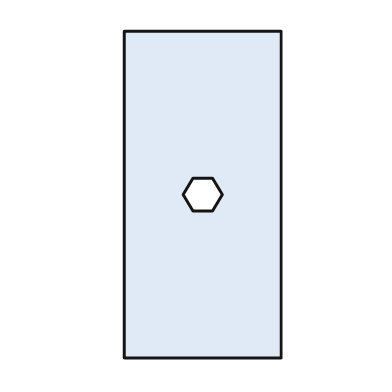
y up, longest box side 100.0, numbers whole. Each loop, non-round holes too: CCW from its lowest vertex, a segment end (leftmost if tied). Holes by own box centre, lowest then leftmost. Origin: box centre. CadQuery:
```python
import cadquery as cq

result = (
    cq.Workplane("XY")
    .moveTo(-24.0, -50.0)
    .lineTo(24.0, -50.0)
    .lineTo(24.0, 50.0)
    .lineTo(-24.0, 50.0)
    .close()
    .moveTo(-3.0, -5.0)
    .lineTo(3.0, -5.0)
    .lineTo(6.0, 0.0)
    .lineTo(3.0, 5.0)
    .lineTo(-3.0, 5.0)
    .lineTo(-6.0, 0.0)
    .close()
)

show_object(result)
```